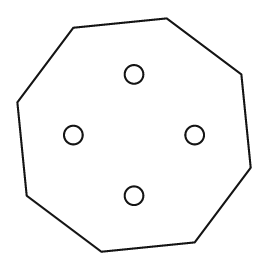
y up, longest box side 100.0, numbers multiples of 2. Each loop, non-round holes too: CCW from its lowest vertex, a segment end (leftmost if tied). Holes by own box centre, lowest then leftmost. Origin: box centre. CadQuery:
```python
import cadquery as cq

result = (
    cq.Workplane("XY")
    .moveTo(-14.0, -50.0)
    .lineTo(26.0, -46.0)
    .lineTo(50.0, -14.0)
    .lineTo(46.0, 26.0)
    .lineTo(14.0, 50.0)
    .lineTo(-26.0, 46.0)
    .lineTo(-50.0, 14.0)
    .lineTo(-46.0, -26.0)
    .close()
    .moveTo(0.0, -26.0)
    .circle(4.0)
    .moveTo(-26.0, 0.0)
    .circle(4.0)
    .moveTo(26.0, 0.0)
    .circle(4.0)
    .moveTo(0.0, 26.0)
    .circle(4.0)
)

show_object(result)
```